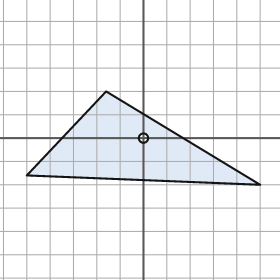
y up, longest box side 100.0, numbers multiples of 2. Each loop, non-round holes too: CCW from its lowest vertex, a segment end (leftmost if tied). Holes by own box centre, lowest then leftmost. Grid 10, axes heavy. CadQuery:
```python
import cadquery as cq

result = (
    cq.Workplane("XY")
    .moveTo(50.0, -20.0)
    .lineTo(-16.0, 20.0)
    .lineTo(-50.0, -16.0)
    .close()
    .moveTo(0.0, 0.0)
    .circle(2.0)
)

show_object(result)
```